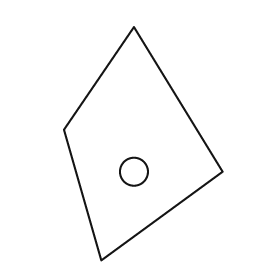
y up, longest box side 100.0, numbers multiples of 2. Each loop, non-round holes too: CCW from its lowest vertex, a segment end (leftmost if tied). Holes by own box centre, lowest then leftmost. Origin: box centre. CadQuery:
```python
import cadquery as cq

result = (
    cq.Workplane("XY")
    .moveTo(-18.0, -50.0)
    .lineTo(34.0, -12.0)
    .lineTo(-4.0, 50.0)
    .lineTo(-34.0, 6.0)
    .close()
    .moveTo(-4.0, -12.0)
    .circle(6.0)
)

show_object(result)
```